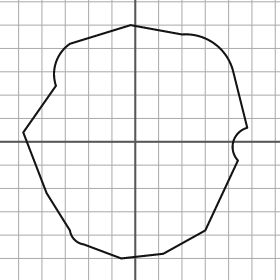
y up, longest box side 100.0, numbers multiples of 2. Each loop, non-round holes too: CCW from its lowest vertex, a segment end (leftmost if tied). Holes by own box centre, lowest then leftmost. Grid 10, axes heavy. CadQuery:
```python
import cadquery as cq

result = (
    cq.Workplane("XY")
    .moveTo(-6.0, -50.0)
    .lineTo(12.0, -48.0)
    .lineTo(30.0, -38.0)
    .lineTo(44.0, -8.0)
    .threePointArc((42.0, 0.0), (48.0, 6.0))
    .lineTo(42.0, 30.0)
    .threePointArc((34.0, 42.0), (20.0, 46.0))
    .lineTo(-2.0, 50.0)
    .lineTo(-28.0, 42.0)
    .threePointArc((-34.0, 34.0), (-34.0, 24.0))
    .lineTo(-48.0, 4.0)
    .lineTo(-38.0, -22.0)
    .lineTo(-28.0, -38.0)
    .threePointArc((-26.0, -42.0), (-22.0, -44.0))
    .close()
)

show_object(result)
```